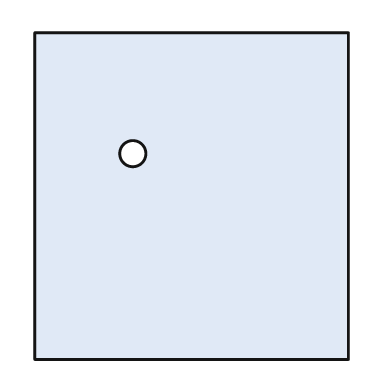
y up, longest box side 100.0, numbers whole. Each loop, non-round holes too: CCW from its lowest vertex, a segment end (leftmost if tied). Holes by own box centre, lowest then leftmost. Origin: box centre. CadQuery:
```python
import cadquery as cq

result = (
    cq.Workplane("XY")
    .moveTo(-48.0, -50.0)
    .lineTo(48.0, -50.0)
    .lineTo(48.0, 50.0)
    .lineTo(-48.0, 50.0)
    .close()
    .moveTo(-18.0, 13.0)
    .circle(4.0)
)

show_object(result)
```